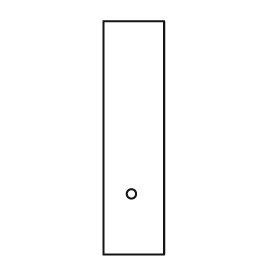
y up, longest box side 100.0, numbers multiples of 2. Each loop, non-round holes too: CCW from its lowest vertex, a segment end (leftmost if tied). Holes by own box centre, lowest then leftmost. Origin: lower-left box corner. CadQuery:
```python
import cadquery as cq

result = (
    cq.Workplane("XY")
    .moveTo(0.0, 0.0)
    .lineTo(26.0, 0.0)
    .lineTo(26.0, 100.0)
    .lineTo(0.0, 100.0)
    .close()
    .moveTo(12.0, 26.0)
    .circle(2.0)
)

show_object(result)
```